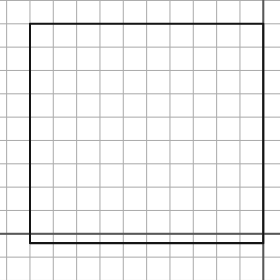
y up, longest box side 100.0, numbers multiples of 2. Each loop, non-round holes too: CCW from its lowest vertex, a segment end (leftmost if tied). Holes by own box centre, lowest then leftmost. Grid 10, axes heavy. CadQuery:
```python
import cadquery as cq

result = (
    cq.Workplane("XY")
    .moveTo(-100.0, -4.0)
    .lineTo(0.0, -4.0)
    .lineTo(0.0, 90.0)
    .lineTo(-100.0, 90.0)
    .close()
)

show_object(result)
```